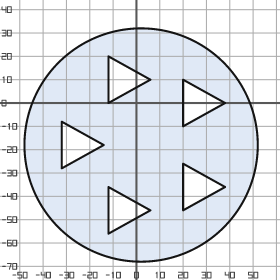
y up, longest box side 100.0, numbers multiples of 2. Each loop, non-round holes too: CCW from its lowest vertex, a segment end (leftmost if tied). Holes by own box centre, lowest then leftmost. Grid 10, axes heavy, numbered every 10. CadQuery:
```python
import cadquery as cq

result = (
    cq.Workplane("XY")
    .moveTo(2.0, -18.0)
    .circle(50.0)
    .moveTo(-12.0, -56.0)
    .lineTo(6.0, -46.0)
    .lineTo(-12.0, -36.0)
    .close()
    .moveTo(20.0, -46.0)
    .lineTo(38.0, -36.0)
    .lineTo(20.0, -26.0)
    .close()
    .moveTo(-32.0, -28.0)
    .lineTo(-14.0, -18.0)
    .lineTo(-32.0, -8.0)
    .close()
    .moveTo(20.0, -10.0)
    .lineTo(38.0, 0.0)
    .lineTo(20.0, 10.0)
    .close()
    .moveTo(-12.0, 0.0)
    .lineTo(6.0, 10.0)
    .lineTo(-12.0, 20.0)
    .close()
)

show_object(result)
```